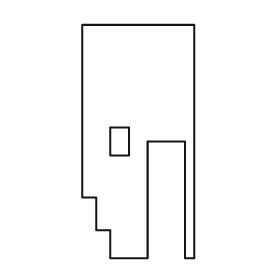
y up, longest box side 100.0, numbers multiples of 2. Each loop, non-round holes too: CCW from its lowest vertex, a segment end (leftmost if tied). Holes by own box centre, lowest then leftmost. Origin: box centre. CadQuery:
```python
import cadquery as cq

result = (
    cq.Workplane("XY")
    .moveTo(-12.0, -50.0)
    .lineTo(4.0, -50.0)
    .lineTo(4.0, 0.0)
    .lineTo(20.0, 0.0)
    .lineTo(20.0, -50.0)
    .lineTo(24.0, -50.0)
    .lineTo(24.0, 50.0)
    .lineTo(-24.0, 50.0)
    .lineTo(-24.0, -24.0)
    .lineTo(-18.0, -24.0)
    .lineTo(-18.0, -38.0)
    .lineTo(-12.0, -38.0)
    .close()
    .moveTo(-12.0, -6.0)
    .lineTo(-4.0, -6.0)
    .lineTo(-4.0, 6.0)
    .lineTo(-12.0, 6.0)
    .close()
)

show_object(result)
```